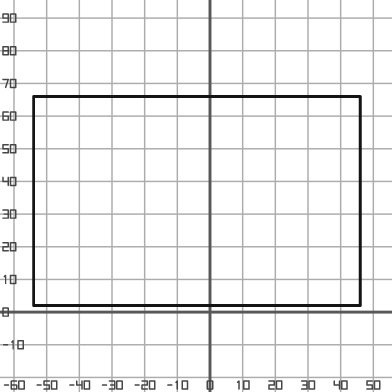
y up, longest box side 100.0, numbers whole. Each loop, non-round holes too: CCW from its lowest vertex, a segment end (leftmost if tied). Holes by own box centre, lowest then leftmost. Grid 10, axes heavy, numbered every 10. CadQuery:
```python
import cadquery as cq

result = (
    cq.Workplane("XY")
    .moveTo(-54.0, 2.0)
    .lineTo(46.0, 2.0)
    .lineTo(46.0, 66.0)
    .lineTo(-54.0, 66.0)
    .close()
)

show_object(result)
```